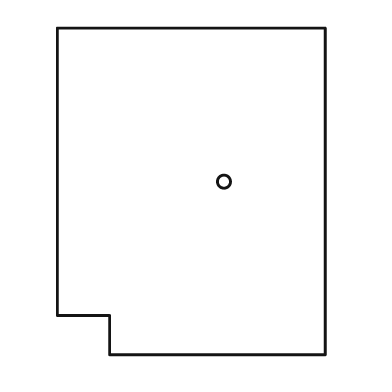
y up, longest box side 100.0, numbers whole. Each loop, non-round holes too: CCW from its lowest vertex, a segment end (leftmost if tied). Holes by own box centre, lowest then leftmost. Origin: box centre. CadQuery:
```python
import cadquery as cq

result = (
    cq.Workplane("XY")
    .moveTo(-25.0, -50.0)
    .lineTo(41.0, -50.0)
    .lineTo(41.0, 50.0)
    .lineTo(-41.0, 50.0)
    .lineTo(-41.0, -38.0)
    .lineTo(-25.0, -38.0)
    .close()
    .moveTo(10.0, 3.0)
    .circle(2.0)
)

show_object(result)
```